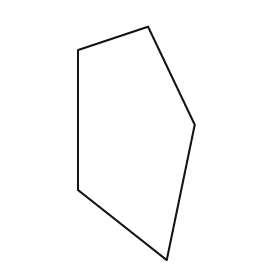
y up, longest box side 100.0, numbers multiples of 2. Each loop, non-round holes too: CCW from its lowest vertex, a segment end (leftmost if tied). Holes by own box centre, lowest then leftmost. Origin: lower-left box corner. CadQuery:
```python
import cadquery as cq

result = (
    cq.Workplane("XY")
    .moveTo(38.0, 0.0)
    .lineTo(50.0, 58.0)
    .lineTo(30.0, 100.0)
    .lineTo(0.0, 90.0)
    .lineTo(0.0, 30.0)
    .close()
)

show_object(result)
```